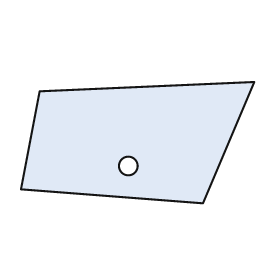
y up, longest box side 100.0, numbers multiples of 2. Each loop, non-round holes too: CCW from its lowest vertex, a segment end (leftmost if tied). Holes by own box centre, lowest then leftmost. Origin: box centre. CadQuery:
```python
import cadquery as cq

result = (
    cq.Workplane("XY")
    .moveTo(28.0, -26.0)
    .lineTo(50.0, 26.0)
    .lineTo(-42.0, 22.0)
    .lineTo(-50.0, -20.0)
    .close()
    .moveTo(-4.0, -10.0)
    .circle(4.0)
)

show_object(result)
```